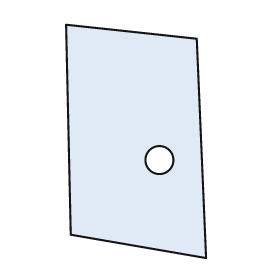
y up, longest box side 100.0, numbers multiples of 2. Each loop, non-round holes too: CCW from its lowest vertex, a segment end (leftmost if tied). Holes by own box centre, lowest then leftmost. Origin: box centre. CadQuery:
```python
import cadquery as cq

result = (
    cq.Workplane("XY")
    .moveTo(30.0, -50.0)
    .lineTo(26.0, 44.0)
    .lineTo(-30.0, 50.0)
    .lineTo(-28.0, -40.0)
    .close()
    .moveTo(10.0, -8.0)
    .circle(6.0)
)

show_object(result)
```